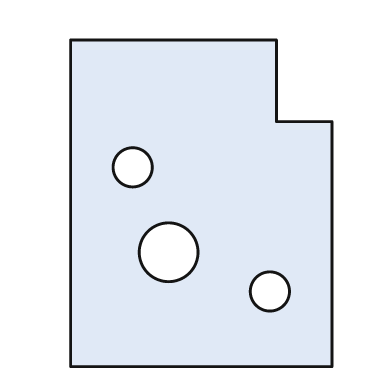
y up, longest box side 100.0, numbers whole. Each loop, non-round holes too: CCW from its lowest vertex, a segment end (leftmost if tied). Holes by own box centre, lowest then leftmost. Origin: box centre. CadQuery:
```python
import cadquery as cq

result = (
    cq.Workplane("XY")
    .moveTo(-40.0, -50.0)
    .lineTo(40.0, -50.0)
    .lineTo(40.0, 25.0)
    .lineTo(23.0, 25.0)
    .lineTo(23.0, 50.0)
    .lineTo(-40.0, 50.0)
    .close()
    .moveTo(21.0, -27.0)
    .circle(6.0)
    .moveTo(-10.0, -15.0)
    .circle(9.0)
    .moveTo(-21.0, 11.0)
    .circle(6.0)
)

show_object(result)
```